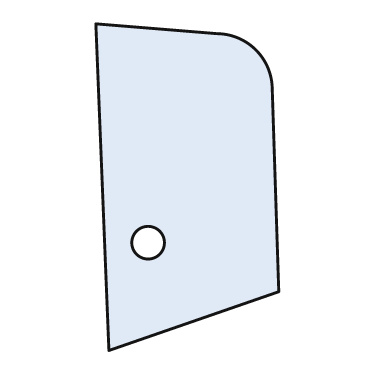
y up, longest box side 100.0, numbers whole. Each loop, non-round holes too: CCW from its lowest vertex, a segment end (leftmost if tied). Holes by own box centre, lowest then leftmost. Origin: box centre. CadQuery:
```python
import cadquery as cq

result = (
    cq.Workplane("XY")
    .moveTo(-24.0, -50.0)
    .lineTo(28.0, -32.0)
    .lineTo(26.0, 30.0)
    .threePointArc((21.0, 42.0), (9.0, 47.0))
    .lineTo(-28.0, 50.0)
    .close()
    .moveTo(-12.0, -17.0)
    .circle(5.0)
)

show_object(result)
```